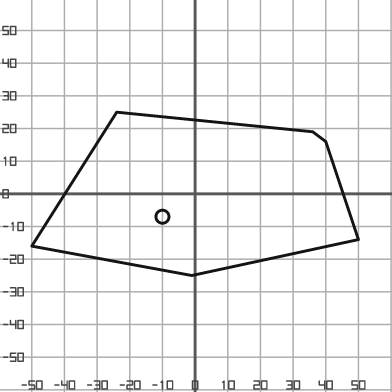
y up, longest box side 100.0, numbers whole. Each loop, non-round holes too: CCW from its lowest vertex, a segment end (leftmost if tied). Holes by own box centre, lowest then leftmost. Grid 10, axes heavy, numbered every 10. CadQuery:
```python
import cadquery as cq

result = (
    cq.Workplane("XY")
    .moveTo(-1.0, -25.0)
    .lineTo(50.0, -14.0)
    .lineTo(40.0, 16.0)
    .lineTo(36.0, 19.0)
    .lineTo(-24.0, 25.0)
    .lineTo(-50.0, -16.0)
    .close()
    .moveTo(-10.0, -7.0)
    .circle(2.0)
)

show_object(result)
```